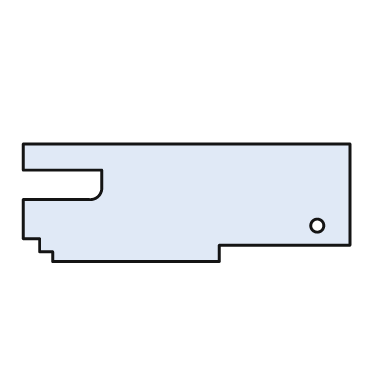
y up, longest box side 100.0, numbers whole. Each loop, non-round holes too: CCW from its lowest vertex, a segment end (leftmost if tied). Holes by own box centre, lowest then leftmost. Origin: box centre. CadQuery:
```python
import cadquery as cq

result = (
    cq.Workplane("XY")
    .moveTo(-41.0, -18.0)
    .lineTo(10.0, -18.0)
    .lineTo(10.0, -13.0)
    .lineTo(50.0, -13.0)
    .lineTo(50.0, 18.0)
    .lineTo(-50.0, 18.0)
    .lineTo(-50.0, 10.0)
    .lineTo(-26.0, 10.0)
    .lineTo(-26.0, 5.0)
    .threePointArc((-27.0, 2.0), (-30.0, 1.0))
    .lineTo(-50.0, 1.0)
    .lineTo(-50.0, -11.0)
    .lineTo(-45.0, -11.0)
    .lineTo(-45.0, -15.0)
    .lineTo(-41.0, -15.0)
    .close()
    .moveTo(40.0, -7.0)
    .circle(2.0)
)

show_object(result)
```